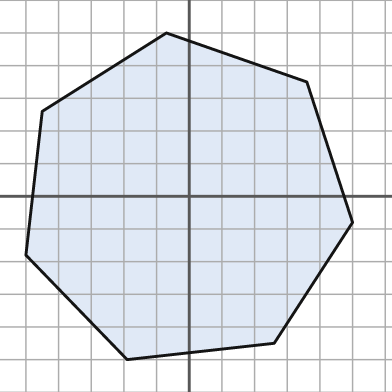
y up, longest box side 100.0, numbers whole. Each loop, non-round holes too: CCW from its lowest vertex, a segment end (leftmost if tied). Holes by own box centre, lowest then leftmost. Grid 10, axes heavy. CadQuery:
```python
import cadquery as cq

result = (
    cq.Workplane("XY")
    .moveTo(-19.0, -50.0)
    .lineTo(26.0, -45.0)
    .lineTo(50.0, -8.0)
    .lineTo(36.0, 35.0)
    .lineTo(-7.0, 50.0)
    .lineTo(-45.0, 26.0)
    .lineTo(-50.0, -18.0)
    .close()
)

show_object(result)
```